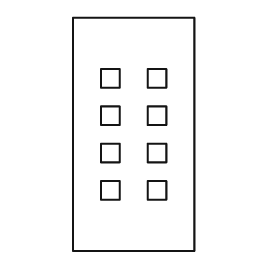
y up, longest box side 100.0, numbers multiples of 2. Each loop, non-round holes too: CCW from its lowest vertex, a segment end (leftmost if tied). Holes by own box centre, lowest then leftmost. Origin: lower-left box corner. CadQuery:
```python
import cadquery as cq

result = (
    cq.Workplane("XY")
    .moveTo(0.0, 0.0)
    .lineTo(52.0, 0.0)
    .lineTo(52.0, 100.0)
    .lineTo(0.0, 100.0)
    .close()
    .moveTo(12.0, 22.0)
    .lineTo(20.0, 22.0)
    .lineTo(20.0, 30.0)
    .lineTo(12.0, 30.0)
    .close()
    .moveTo(32.0, 22.0)
    .lineTo(40.0, 22.0)
    .lineTo(40.0, 30.0)
    .lineTo(32.0, 30.0)
    .close()
    .moveTo(12.0, 38.0)
    .lineTo(20.0, 38.0)
    .lineTo(20.0, 46.0)
    .lineTo(12.0, 46.0)
    .close()
    .moveTo(32.0, 38.0)
    .lineTo(40.0, 38.0)
    .lineTo(40.0, 46.0)
    .lineTo(32.0, 46.0)
    .close()
    .moveTo(12.0, 54.0)
    .lineTo(20.0, 54.0)
    .lineTo(20.0, 62.0)
    .lineTo(12.0, 62.0)
    .close()
    .moveTo(32.0, 54.0)
    .lineTo(40.0, 54.0)
    .lineTo(40.0, 62.0)
    .lineTo(32.0, 62.0)
    .close()
    .moveTo(12.0, 70.0)
    .lineTo(20.0, 70.0)
    .lineTo(20.0, 78.0)
    .lineTo(12.0, 78.0)
    .close()
    .moveTo(32.0, 70.0)
    .lineTo(40.0, 70.0)
    .lineTo(40.0, 78.0)
    .lineTo(32.0, 78.0)
    .close()
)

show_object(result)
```